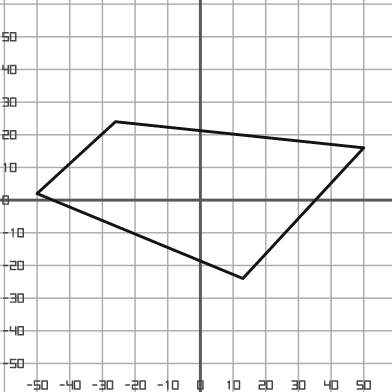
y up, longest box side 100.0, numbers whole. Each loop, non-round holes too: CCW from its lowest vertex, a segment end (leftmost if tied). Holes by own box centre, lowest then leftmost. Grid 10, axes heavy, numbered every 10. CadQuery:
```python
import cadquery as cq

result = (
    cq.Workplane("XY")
    .moveTo(13.0, -24.0)
    .lineTo(50.0, 16.0)
    .lineTo(-26.0, 24.0)
    .lineTo(-50.0, 2.0)
    .close()
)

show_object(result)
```